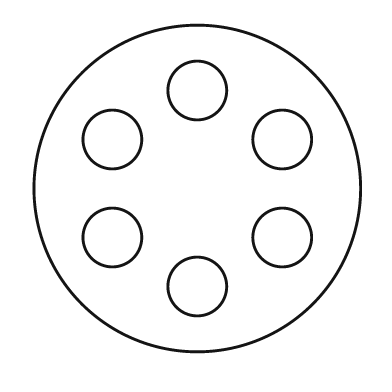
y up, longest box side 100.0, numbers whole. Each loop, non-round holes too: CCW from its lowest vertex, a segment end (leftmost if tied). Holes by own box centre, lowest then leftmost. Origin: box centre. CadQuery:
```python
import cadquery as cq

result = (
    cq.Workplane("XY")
    .moveTo(0.0, 0.0)
    .circle(50.0)
    .moveTo(0.0, -30.0)
    .circle(9.0)
    .moveTo(-26.0, -15.0)
    .circle(9.0)
    .moveTo(26.0, -15.0)
    .circle(9.0)
    .moveTo(-26.0, 15.0)
    .circle(9.0)
    .moveTo(26.0, 15.0)
    .circle(9.0)
    .moveTo(0.0, 30.0)
    .circle(9.0)
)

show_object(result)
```